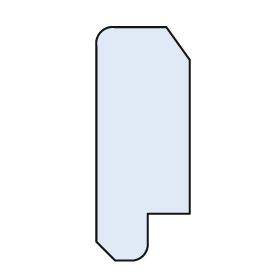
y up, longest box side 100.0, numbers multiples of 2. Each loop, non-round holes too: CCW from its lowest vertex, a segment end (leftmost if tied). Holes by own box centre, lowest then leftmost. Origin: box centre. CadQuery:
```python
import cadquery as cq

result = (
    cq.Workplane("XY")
    .moveTo(-12.0, -50.0)
    .lineTo(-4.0, -50.0)
    .threePointArc((0.0, -48.0), (2.0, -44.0))
    .lineTo(2.0, -30.0)
    .lineTo(20.0, -30.0)
    .lineTo(20.0, 36.0)
    .lineTo(10.0, 50.0)
    .lineTo(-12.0, 50.0)
    .threePointArc((-18.0, 48.0), (-20.0, 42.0))
    .lineTo(-20.0, -42.0)
    .close()
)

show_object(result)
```